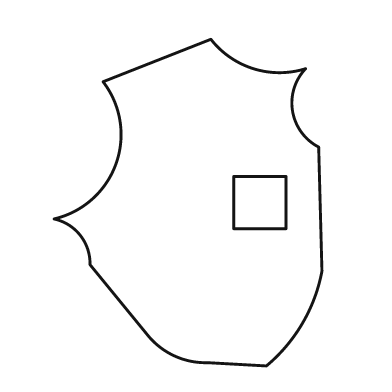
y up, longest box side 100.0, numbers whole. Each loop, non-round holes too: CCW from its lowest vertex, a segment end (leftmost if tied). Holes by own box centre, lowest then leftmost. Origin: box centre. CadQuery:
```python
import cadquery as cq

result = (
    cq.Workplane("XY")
    .moveTo(24.0, -50.0)
    .threePointArc((35.0, -37.0), (41.0, -21.0))
    .lineTo(40.0, 17.0)
    .threePointArc((32.0, 28.0), (36.0, 41.0))
    .threePointArc((20.0, 41.0), (7.0, 50.0))
    .lineTo(-26.0, 37.0)
    .threePointArc((-22.0, 12.0), (-41.0, -5.0))
    .threePointArc((-33.0, -10.0), (-30.0, -19.0))
    .lineTo(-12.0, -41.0)
    .threePointArc((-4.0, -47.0), (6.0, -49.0))
    .close()
    .moveTo(14.0, -8.0)
    .lineTo(30.0, -8.0)
    .lineTo(30.0, 8.0)
    .lineTo(14.0, 8.0)
    .close()
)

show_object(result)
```